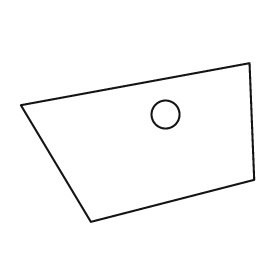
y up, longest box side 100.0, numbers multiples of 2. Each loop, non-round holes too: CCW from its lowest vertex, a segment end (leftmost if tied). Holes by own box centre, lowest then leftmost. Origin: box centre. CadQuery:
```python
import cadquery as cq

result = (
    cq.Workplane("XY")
    .moveTo(-20.0, -34.0)
    .lineTo(50.0, -16.0)
    .lineTo(48.0, 34.0)
    .lineTo(-50.0, 16.0)
    .close()
    .moveTo(12.0, 12.0)
    .circle(6.0)
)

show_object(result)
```